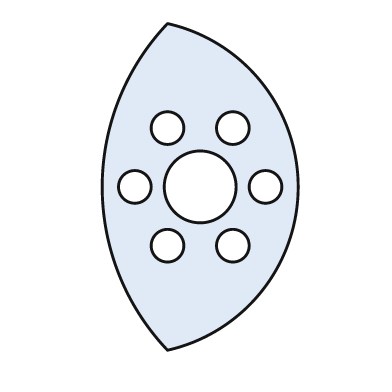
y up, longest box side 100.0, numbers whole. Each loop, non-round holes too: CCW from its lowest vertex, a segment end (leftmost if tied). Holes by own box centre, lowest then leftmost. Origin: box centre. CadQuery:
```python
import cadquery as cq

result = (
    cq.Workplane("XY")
    .moveTo(-10.0, -50.0)
    .threePointArc((30.0, 0.0), (-10.0, 50.0))
    .threePointArc((-30.0, 0.0), (-10.0, -50.0))
    .close()
    .moveTo(-10.0, -18.0)
    .circle(5.0)
    .moveTo(10.0, -18.0)
    .circle(5.0)
    .moveTo(-20.0, 0.0)
    .circle(5.0)
    .moveTo(0.0, 0.0)
    .circle(11.0)
    .moveTo(20.0, 0.0)
    .circle(5.0)
    .moveTo(-10.0, 18.0)
    .circle(5.0)
    .moveTo(10.0, 18.0)
    .circle(5.0)
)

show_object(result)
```